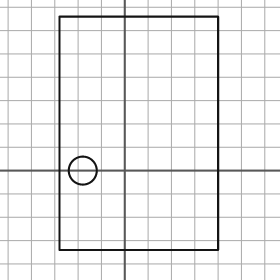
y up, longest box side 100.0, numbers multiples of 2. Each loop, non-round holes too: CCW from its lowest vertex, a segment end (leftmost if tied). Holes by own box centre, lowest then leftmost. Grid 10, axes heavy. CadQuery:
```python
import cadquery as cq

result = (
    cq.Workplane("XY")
    .moveTo(-28.0, -34.0)
    .lineTo(40.0, -34.0)
    .lineTo(40.0, 66.0)
    .lineTo(-28.0, 66.0)
    .close()
    .moveTo(-18.0, 0.0)
    .circle(6.0)
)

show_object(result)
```